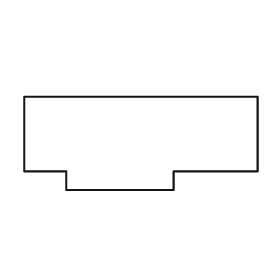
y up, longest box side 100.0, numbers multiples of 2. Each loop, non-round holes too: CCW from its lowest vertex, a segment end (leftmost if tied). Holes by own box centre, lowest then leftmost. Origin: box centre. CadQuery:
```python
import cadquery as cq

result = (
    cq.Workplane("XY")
    .moveTo(-32.0, -20.0)
    .lineTo(14.0, -20.0)
    .lineTo(14.0, -12.0)
    .lineTo(50.0, -12.0)
    .lineTo(50.0, 20.0)
    .lineTo(-50.0, 20.0)
    .lineTo(-50.0, -12.0)
    .lineTo(-32.0, -12.0)
    .close()
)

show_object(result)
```